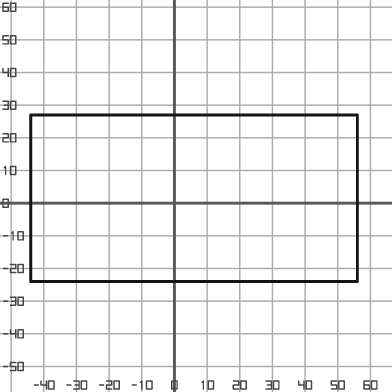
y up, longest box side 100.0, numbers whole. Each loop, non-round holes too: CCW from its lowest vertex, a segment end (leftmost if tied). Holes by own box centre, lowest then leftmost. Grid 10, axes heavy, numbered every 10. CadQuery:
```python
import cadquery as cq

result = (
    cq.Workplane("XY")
    .moveTo(-44.0, -24.0)
    .lineTo(56.0, -24.0)
    .lineTo(56.0, 27.0)
    .lineTo(-44.0, 27.0)
    .close()
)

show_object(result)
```